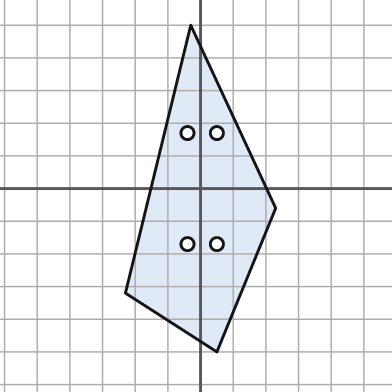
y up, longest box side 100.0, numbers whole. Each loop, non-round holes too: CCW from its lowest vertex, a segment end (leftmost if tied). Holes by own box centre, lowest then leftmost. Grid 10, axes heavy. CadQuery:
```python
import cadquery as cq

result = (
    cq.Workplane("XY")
    .moveTo(5.0, -50.0)
    .lineTo(23.0, -6.0)
    .lineTo(-3.0, 50.0)
    .lineTo(-23.0, -32.0)
    .close()
    .moveTo(-4.0, -17.0)
    .circle(2.0)
    .moveTo(5.0, -17.0)
    .circle(2.0)
    .moveTo(-4.0, 17.0)
    .circle(2.0)
    .moveTo(5.0, 17.0)
    .circle(2.0)
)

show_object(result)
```